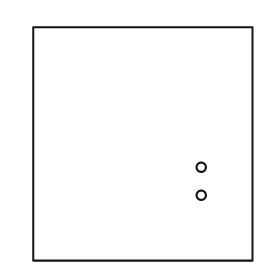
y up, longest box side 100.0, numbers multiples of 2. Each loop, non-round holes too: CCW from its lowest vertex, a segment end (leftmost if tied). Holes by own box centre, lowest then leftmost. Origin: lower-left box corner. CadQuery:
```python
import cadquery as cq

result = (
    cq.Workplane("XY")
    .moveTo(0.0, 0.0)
    .lineTo(94.0, 0.0)
    .lineTo(94.0, 100.0)
    .lineTo(0.0, 100.0)
    .close()
    .moveTo(72.0, 28.0)
    .circle(2.0)
    .moveTo(72.0, 40.0)
    .circle(2.0)
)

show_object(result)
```